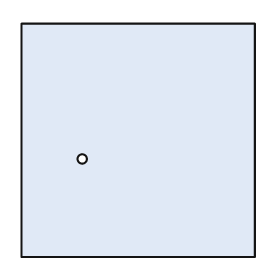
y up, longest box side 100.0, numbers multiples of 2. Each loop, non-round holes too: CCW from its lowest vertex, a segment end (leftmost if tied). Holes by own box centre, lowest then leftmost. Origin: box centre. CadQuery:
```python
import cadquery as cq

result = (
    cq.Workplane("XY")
    .moveTo(-50.0, -50.0)
    .lineTo(50.0, -50.0)
    .lineTo(50.0, 50.0)
    .lineTo(-50.0, 50.0)
    .close()
    .moveTo(-24.0, -8.0)
    .circle(2.0)
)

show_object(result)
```